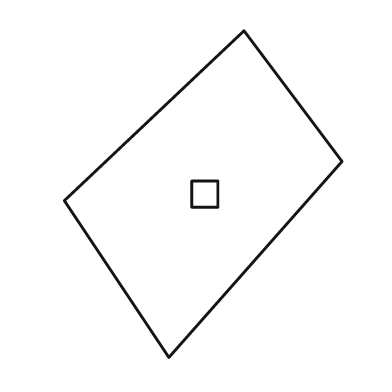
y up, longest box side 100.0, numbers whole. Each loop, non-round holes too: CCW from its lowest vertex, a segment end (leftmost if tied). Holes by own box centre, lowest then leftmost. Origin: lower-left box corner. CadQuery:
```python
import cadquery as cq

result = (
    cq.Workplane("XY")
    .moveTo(32.0, 0.0)
    .lineTo(85.0, 60.0)
    .lineTo(55.0, 100.0)
    .lineTo(0.0, 48.0)
    .close()
    .moveTo(39.0, 46.0)
    .lineTo(47.0, 46.0)
    .lineTo(47.0, 54.0)
    .lineTo(39.0, 54.0)
    .close()
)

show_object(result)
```